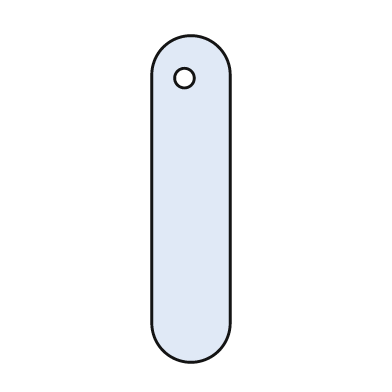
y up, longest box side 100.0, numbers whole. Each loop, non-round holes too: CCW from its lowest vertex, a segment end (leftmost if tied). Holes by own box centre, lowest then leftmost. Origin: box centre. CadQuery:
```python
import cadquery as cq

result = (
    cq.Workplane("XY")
    .moveTo(-12.0, -38.0)
    .threePointArc((0.0, -50.0), (12.0, -38.0))
    .lineTo(12.0, 38.0)
    .threePointArc((0.0, 50.0), (-12.0, 38.0))
    .close()
    .moveTo(-2.0, 37.0)
    .circle(3.0)
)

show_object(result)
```